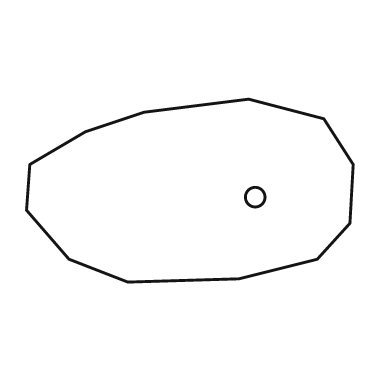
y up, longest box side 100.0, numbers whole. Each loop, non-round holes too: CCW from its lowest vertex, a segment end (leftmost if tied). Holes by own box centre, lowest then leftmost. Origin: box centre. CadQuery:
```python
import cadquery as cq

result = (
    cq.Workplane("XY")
    .moveTo(-19.0, -28.0)
    .lineTo(15.0, -27.0)
    .lineTo(39.0, -21.0)
    .lineTo(49.0, -10.0)
    .lineTo(50.0, 8.0)
    .lineTo(41.0, 22.0)
    .lineTo(18.0, 28.0)
    .lineTo(-14.0, 24.0)
    .lineTo(-32.0, 18.0)
    .lineTo(-49.0, 8.0)
    .lineTo(-50.0, -6.0)
    .lineTo(-37.0, -21.0)
    .close()
    .moveTo(20.0, -2.0)
    .circle(3.0)
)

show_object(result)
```